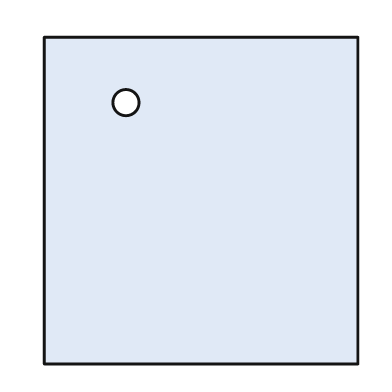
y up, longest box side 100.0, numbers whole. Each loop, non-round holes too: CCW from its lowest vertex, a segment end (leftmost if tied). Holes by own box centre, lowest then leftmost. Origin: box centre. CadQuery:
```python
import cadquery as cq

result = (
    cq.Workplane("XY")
    .moveTo(-48.0, -50.0)
    .lineTo(48.0, -50.0)
    .lineTo(48.0, 50.0)
    .lineTo(-48.0, 50.0)
    .close()
    .moveTo(-23.0, 30.0)
    .circle(4.0)
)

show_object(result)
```